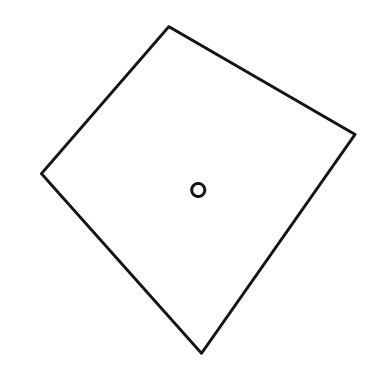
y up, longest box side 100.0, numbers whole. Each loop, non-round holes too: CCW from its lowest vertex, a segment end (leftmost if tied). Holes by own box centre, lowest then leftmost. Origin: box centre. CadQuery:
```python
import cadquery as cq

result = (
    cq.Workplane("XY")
    .moveTo(1.0, -50.0)
    .lineTo(48.0, 17.0)
    .lineTo(-9.0, 50.0)
    .lineTo(-48.0, 5.0)
    .close()
    .moveTo(0.0, 0.0)
    .circle(2.0)
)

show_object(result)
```